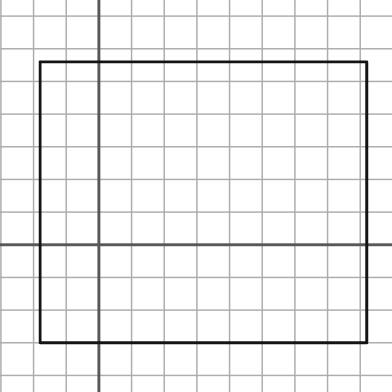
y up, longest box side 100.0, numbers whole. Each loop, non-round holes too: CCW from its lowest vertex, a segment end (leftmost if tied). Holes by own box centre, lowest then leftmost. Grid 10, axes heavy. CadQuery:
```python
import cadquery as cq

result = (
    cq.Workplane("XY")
    .moveTo(-18.0, -30.0)
    .lineTo(82.0, -30.0)
    .lineTo(82.0, 56.0)
    .lineTo(-18.0, 56.0)
    .close()
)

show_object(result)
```